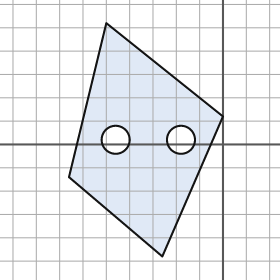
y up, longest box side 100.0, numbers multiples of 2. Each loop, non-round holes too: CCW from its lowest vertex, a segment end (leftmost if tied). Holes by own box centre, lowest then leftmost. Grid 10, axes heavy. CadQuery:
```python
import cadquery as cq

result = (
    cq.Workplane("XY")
    .moveTo(-26.0, -48.0)
    .lineTo(0.0, 12.0)
    .lineTo(-50.0, 52.0)
    .lineTo(-66.0, -14.0)
    .close()
    .moveTo(-46.0, 2.0)
    .circle(6.0)
    .moveTo(-18.0, 2.0)
    .circle(6.0)
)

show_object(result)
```